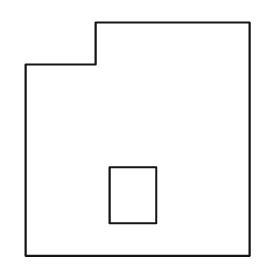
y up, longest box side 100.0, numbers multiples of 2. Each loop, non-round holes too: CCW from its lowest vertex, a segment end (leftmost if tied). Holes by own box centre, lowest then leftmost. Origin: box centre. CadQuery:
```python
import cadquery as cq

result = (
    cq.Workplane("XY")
    .moveTo(-48.0, -50.0)
    .lineTo(48.0, -50.0)
    .lineTo(48.0, 50.0)
    .lineTo(-18.0, 50.0)
    .lineTo(-18.0, 32.0)
    .lineTo(-48.0, 32.0)
    .close()
    .moveTo(-12.0, -36.0)
    .lineTo(8.0, -36.0)
    .lineTo(8.0, -12.0)
    .lineTo(-12.0, -12.0)
    .close()
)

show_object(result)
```